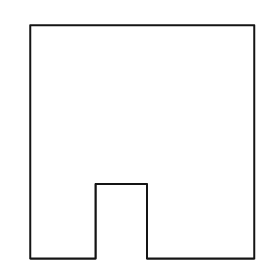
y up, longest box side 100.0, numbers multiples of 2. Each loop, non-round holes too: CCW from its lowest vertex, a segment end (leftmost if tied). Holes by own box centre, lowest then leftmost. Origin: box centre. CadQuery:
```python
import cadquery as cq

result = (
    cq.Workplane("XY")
    .moveTo(-48.0, -50.0)
    .lineTo(-20.0, -50.0)
    .lineTo(-20.0, -18.0)
    .lineTo(2.0, -18.0)
    .lineTo(2.0, -50.0)
    .lineTo(48.0, -50.0)
    .lineTo(48.0, 50.0)
    .lineTo(-48.0, 50.0)
    .close()
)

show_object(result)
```